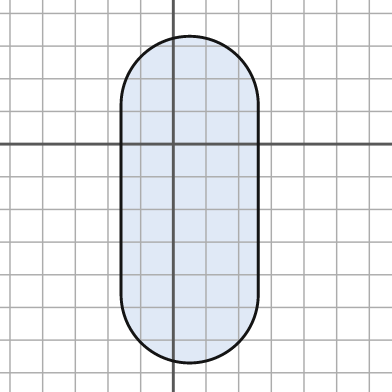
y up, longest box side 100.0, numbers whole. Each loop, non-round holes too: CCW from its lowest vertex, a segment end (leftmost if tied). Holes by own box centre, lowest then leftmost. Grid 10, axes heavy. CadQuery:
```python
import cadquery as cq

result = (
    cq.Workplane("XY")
    .moveTo(-16.0, -46.0)
    .threePointArc((5.0, -67.0), (26.0, -46.0))
    .lineTo(26.0, 12.0)
    .threePointArc((5.0, 33.0), (-16.0, 12.0))
    .close()
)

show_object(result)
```